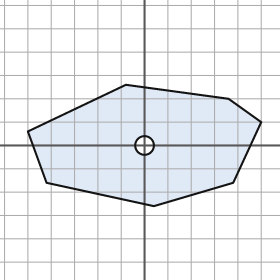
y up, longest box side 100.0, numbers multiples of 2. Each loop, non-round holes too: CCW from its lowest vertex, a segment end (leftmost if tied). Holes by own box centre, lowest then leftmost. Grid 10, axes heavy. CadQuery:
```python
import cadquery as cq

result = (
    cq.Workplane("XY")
    .moveTo(4.0, -26.0)
    .lineTo(38.0, -16.0)
    .lineTo(50.0, 10.0)
    .lineTo(36.0, 20.0)
    .lineTo(-8.0, 26.0)
    .lineTo(-50.0, 6.0)
    .lineTo(-42.0, -16.0)
    .close()
    .moveTo(0.0, 0.0)
    .circle(4.0)
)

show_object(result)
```